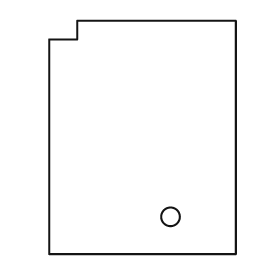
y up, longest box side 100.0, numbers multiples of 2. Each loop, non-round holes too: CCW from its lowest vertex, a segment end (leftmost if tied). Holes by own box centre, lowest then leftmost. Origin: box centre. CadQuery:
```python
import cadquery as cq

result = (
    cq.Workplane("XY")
    .moveTo(-40.0, -50.0)
    .lineTo(40.0, -50.0)
    .lineTo(40.0, 50.0)
    .lineTo(-28.0, 50.0)
    .lineTo(-28.0, 42.0)
    .lineTo(-40.0, 42.0)
    .close()
    .moveTo(12.0, -34.0)
    .circle(4.0)
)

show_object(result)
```